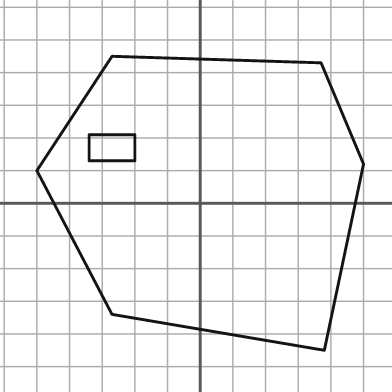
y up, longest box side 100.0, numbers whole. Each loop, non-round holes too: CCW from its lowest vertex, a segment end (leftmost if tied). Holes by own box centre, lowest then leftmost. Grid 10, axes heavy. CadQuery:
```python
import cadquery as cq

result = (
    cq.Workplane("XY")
    .moveTo(38.0, -45.0)
    .lineTo(50.0, 12.0)
    .lineTo(37.0, 43.0)
    .lineTo(-27.0, 45.0)
    .lineTo(-50.0, 10.0)
    .lineTo(-27.0, -34.0)
    .close()
    .moveTo(-34.0, 13.0)
    .lineTo(-20.0, 13.0)
    .lineTo(-20.0, 21.0)
    .lineTo(-34.0, 21.0)
    .close()
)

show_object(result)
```